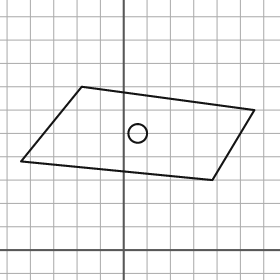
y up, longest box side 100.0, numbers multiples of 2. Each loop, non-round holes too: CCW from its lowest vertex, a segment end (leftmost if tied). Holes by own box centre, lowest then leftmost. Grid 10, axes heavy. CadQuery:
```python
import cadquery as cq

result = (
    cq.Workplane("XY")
    .moveTo(38.0, 30.0)
    .lineTo(56.0, 60.0)
    .lineTo(-18.0, 70.0)
    .lineTo(-44.0, 38.0)
    .close()
    .moveTo(6.0, 50.0)
    .circle(4.0)
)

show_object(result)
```